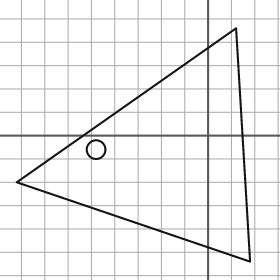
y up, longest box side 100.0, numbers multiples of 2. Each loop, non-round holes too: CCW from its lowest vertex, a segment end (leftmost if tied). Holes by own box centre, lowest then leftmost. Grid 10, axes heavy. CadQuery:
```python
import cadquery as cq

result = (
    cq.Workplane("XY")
    .moveTo(18.0, -54.0)
    .lineTo(12.0, 46.0)
    .lineTo(-82.0, -20.0)
    .close()
    .moveTo(-48.0, -6.0)
    .circle(4.0)
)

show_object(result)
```